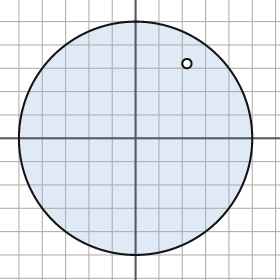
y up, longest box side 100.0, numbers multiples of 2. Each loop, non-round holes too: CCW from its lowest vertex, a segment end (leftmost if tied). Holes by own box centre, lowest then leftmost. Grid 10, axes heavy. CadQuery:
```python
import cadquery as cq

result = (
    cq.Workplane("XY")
    .moveTo(0.0, 0.0)
    .circle(50.0)
    .moveTo(22.0, 32.0)
    .circle(2.0)
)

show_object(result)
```